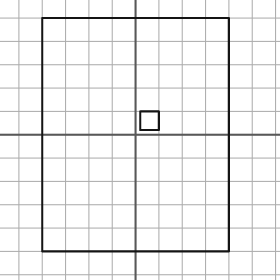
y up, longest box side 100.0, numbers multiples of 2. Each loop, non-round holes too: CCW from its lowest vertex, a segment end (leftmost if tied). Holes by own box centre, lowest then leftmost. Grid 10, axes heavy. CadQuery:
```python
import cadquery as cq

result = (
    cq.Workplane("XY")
    .moveTo(-40.0, -50.0)
    .lineTo(40.0, -50.0)
    .lineTo(40.0, 50.0)
    .lineTo(-40.0, 50.0)
    .close()
    .moveTo(2.0, 2.0)
    .lineTo(10.0, 2.0)
    .lineTo(10.0, 10.0)
    .lineTo(2.0, 10.0)
    .close()
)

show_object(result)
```